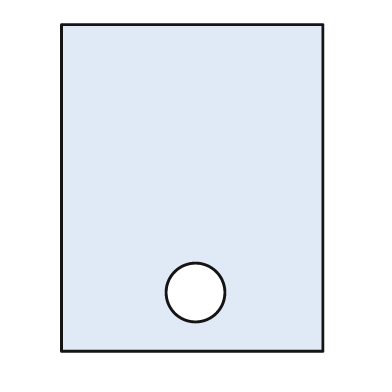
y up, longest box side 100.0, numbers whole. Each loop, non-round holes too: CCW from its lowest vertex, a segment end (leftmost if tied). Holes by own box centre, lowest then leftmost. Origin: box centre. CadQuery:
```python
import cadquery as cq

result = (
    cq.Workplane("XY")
    .moveTo(-40.0, -50.0)
    .lineTo(40.0, -50.0)
    .lineTo(40.0, 50.0)
    .lineTo(-40.0, 50.0)
    .close()
    .moveTo(1.0, -32.0)
    .circle(9.0)
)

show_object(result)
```